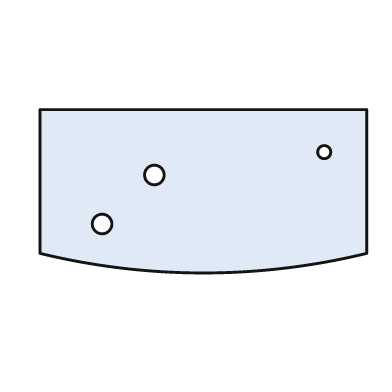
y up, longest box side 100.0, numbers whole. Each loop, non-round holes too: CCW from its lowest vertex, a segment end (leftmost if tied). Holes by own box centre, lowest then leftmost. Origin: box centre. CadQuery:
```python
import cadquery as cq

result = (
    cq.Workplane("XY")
    .moveTo(-50.0, -19.0)
    .threePointArc((0.0, -25.0), (50.0, -19.0))
    .lineTo(50.0, 25.0)
    .lineTo(-50.0, 25.0)
    .close()
    .moveTo(-31.0, -10.0)
    .circle(3.0)
    .moveTo(-15.0, 5.0)
    .circle(3.0)
    .moveTo(37.0, 12.0)
    .circle(2.0)
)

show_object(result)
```